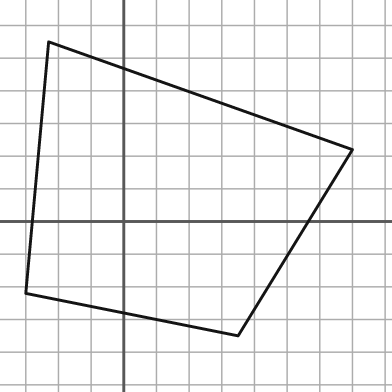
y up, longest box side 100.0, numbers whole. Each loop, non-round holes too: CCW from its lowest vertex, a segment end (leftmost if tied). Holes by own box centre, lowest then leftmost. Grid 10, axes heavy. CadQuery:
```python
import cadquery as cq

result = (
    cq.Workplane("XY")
    .moveTo(35.0, -35.0)
    .lineTo(70.0, 22.0)
    .lineTo(-23.0, 55.0)
    .lineTo(-30.0, -22.0)
    .close()
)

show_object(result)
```